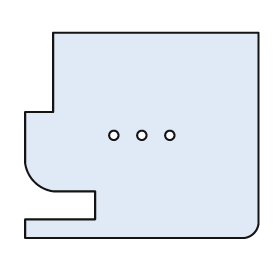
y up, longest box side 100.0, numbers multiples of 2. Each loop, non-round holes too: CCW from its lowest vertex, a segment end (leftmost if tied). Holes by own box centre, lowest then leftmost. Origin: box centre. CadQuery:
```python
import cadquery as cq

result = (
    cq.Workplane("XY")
    .moveTo(-50.0, -44.0)
    .lineTo(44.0, -44.0)
    .threePointArc((48.0, -42.0), (50.0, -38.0))
    .lineTo(50.0, 44.0)
    .lineTo(-38.0, 44.0)
    .lineTo(-38.0, 10.0)
    .lineTo(-50.0, 10.0)
    .lineTo(-50.0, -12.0)
    .threePointArc((-46.0, -20.0), (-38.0, -24.0))
    .lineTo(-20.0, -24.0)
    .lineTo(-20.0, -36.0)
    .lineTo(-50.0, -36.0)
    .close()
    .moveTo(-12.0, 0.0)
    .circle(2.0)
    .moveTo(0.0, 0.0)
    .circle(2.0)
    .moveTo(12.0, 0.0)
    .circle(2.0)
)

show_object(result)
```